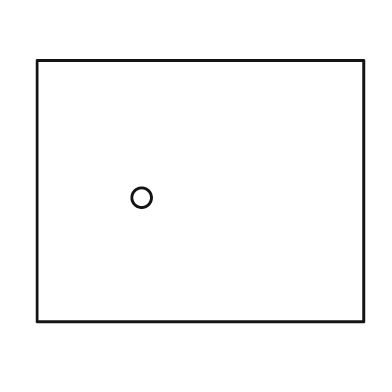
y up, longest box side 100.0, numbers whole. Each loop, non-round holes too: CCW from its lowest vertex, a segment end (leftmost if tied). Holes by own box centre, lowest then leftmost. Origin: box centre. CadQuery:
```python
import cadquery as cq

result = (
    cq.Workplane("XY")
    .moveTo(-50.0, -40.0)
    .lineTo(50.0, -40.0)
    .lineTo(50.0, 40.0)
    .lineTo(-50.0, 40.0)
    .close()
    .moveTo(-18.0, -2.0)
    .circle(3.0)
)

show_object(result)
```